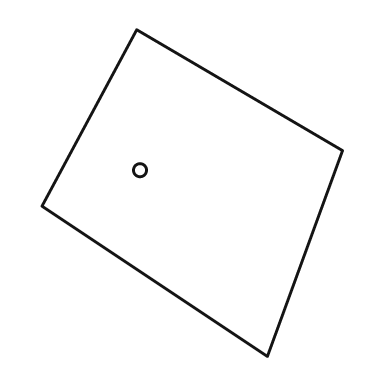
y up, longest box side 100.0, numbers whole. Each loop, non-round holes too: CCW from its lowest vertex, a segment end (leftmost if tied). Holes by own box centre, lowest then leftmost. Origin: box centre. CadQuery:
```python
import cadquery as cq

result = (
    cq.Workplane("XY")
    .moveTo(23.0, -50.0)
    .lineTo(46.0, 13.0)
    .lineTo(-17.0, 50.0)
    .lineTo(-46.0, -4.0)
    .close()
    .moveTo(-16.0, 7.0)
    .circle(2.0)
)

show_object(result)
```